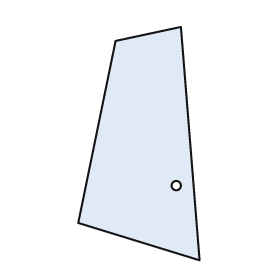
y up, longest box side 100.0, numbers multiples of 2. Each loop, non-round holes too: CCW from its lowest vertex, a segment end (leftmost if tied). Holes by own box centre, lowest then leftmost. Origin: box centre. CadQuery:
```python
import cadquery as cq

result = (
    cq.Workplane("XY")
    .moveTo(26.0, -50.0)
    .lineTo(18.0, 50.0)
    .lineTo(-10.0, 44.0)
    .lineTo(-26.0, -34.0)
    .close()
    .moveTo(16.0, -18.0)
    .circle(2.0)
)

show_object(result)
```